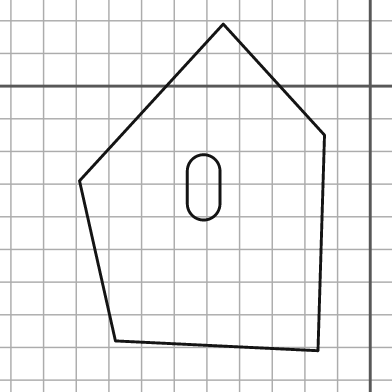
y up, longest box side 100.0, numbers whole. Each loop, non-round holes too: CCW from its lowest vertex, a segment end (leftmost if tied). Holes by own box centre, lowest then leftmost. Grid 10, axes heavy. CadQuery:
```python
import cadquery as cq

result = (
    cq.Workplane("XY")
    .moveTo(-16.0, -81.0)
    .lineTo(-14.0, -15.0)
    .lineTo(-45.0, 19.0)
    .lineTo(-89.0, -29.0)
    .lineTo(-78.0, -78.0)
    .close()
    .moveTo(-56.0, -36.0)
    .threePointArc((-51.0, -41.0), (-46.0, -36.0))
    .lineTo(-46.0, -26.0)
    .threePointArc((-51.0, -21.0), (-56.0, -26.0))
    .close()
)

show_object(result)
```